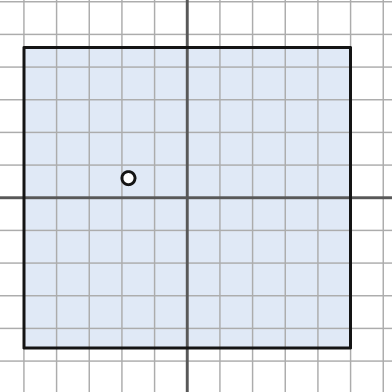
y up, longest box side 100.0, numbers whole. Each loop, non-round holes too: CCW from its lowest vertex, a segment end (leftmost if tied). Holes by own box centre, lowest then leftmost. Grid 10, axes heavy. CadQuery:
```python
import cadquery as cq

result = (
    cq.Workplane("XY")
    .moveTo(-50.0, -46.0)
    .lineTo(50.0, -46.0)
    .lineTo(50.0, 46.0)
    .lineTo(-50.0, 46.0)
    .close()
    .moveTo(-18.0, 6.0)
    .circle(2.0)
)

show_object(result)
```